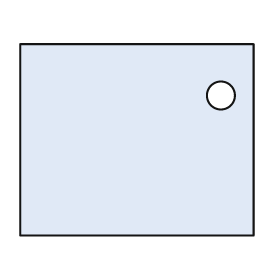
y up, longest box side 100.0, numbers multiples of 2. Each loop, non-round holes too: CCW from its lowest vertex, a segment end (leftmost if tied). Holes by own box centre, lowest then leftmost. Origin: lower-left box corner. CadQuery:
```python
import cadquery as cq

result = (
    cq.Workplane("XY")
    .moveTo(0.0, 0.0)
    .lineTo(100.0, 0.0)
    .lineTo(100.0, 82.0)
    .lineTo(0.0, 82.0)
    .close()
    .moveTo(86.0, 60.0)
    .circle(6.0)
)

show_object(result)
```